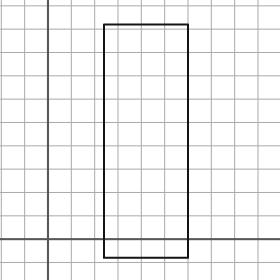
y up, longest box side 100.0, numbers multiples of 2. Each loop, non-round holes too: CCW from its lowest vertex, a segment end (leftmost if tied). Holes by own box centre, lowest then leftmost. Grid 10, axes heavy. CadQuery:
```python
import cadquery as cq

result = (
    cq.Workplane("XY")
    .moveTo(24.0, -8.0)
    .lineTo(60.0, -8.0)
    .lineTo(60.0, 92.0)
    .lineTo(24.0, 92.0)
    .close()
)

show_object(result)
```